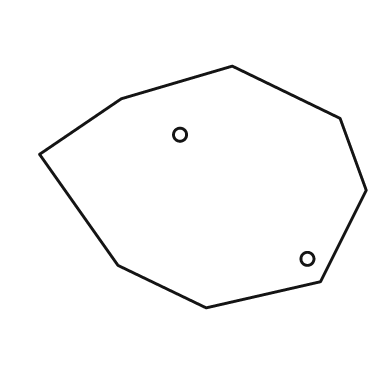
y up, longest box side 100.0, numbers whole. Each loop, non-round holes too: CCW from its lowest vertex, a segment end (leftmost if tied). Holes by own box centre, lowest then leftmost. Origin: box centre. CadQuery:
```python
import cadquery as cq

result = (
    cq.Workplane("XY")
    .moveTo(1.0, -37.0)
    .lineTo(36.0, -29.0)
    .lineTo(50.0, -1.0)
    .lineTo(42.0, 21.0)
    .lineTo(9.0, 37.0)
    .lineTo(-25.0, 27.0)
    .lineTo(-50.0, 10.0)
    .lineTo(-26.0, -24.0)
    .close()
    .moveTo(32.0, -22.0)
    .circle(2.0)
    .moveTo(-7.0, 16.0)
    .circle(2.0)
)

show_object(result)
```